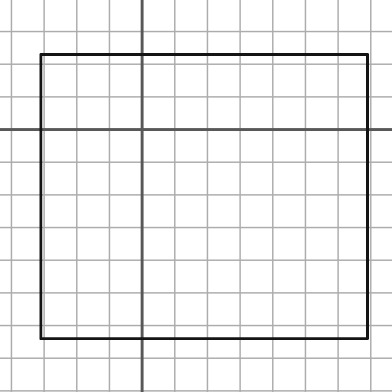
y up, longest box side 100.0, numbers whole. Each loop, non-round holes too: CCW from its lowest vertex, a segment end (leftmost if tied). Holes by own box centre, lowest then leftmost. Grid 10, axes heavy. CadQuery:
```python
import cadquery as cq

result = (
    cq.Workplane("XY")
    .moveTo(-31.0, -64.0)
    .lineTo(69.0, -64.0)
    .lineTo(69.0, 23.0)
    .lineTo(-31.0, 23.0)
    .close()
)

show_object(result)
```